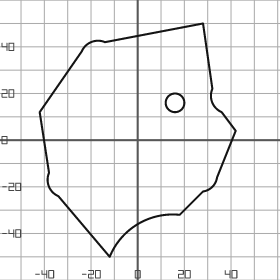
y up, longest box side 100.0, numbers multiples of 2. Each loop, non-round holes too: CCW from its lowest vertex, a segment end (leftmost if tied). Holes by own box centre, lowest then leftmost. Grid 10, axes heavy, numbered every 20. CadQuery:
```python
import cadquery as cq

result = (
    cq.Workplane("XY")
    .moveTo(-12.0, -50.0)
    .threePointArc((0.0, -36.0), (18.0, -32.0))
    .lineTo(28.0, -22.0)
    .threePointArc((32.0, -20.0), (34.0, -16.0))
    .lineTo(42.0, 4.0)
    .lineTo(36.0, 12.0)
    .threePointArc((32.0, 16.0), (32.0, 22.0))
    .lineTo(28.0, 50.0)
    .lineTo(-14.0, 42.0)
    .threePointArc((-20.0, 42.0), (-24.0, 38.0))
    .lineTo(-42.0, 12.0)
    .lineTo(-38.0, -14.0)
    .threePointArc((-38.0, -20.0), (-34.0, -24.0))
    .close()
    .moveTo(16.0, 16.0)
    .circle(4.0)
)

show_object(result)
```